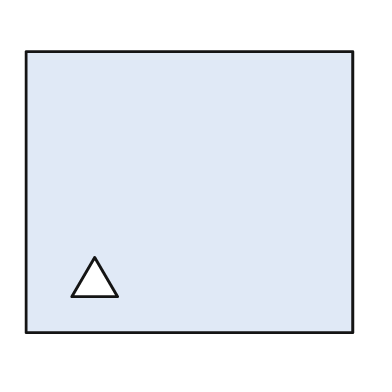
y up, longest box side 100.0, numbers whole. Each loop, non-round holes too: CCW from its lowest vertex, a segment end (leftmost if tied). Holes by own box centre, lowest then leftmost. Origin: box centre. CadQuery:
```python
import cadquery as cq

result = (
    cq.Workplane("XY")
    .moveTo(-50.0, -43.0)
    .lineTo(50.0, -43.0)
    .lineTo(50.0, 43.0)
    .lineTo(-50.0, 43.0)
    .close()
    .moveTo(-36.0, -32.0)
    .lineTo(-22.0, -32.0)
    .lineTo(-29.0, -20.0)
    .close()
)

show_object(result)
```